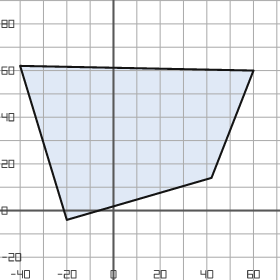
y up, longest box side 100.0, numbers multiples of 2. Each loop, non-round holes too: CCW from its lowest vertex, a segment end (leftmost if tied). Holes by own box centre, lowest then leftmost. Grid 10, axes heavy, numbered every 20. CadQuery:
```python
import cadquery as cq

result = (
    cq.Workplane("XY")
    .moveTo(-20.0, -4.0)
    .lineTo(42.0, 14.0)
    .lineTo(60.0, 60.0)
    .lineTo(-40.0, 62.0)
    .close()
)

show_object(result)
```